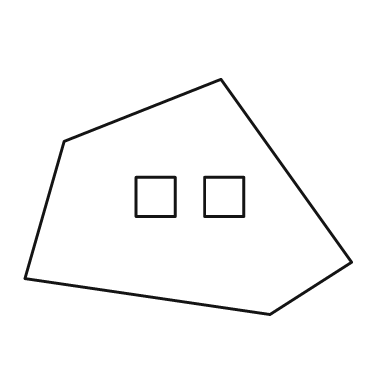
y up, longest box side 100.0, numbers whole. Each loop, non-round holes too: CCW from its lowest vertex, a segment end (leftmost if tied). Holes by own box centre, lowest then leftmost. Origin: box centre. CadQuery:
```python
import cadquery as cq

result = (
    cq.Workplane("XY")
    .moveTo(25.0, -36.0)
    .lineTo(50.0, -20.0)
    .lineTo(10.0, 36.0)
    .lineTo(-38.0, 17.0)
    .lineTo(-50.0, -25.0)
    .close()
    .moveTo(-16.0, -6.0)
    .lineTo(-4.0, -6.0)
    .lineTo(-4.0, 6.0)
    .lineTo(-16.0, 6.0)
    .close()
    .moveTo(5.0, -6.0)
    .lineTo(17.0, -6.0)
    .lineTo(17.0, 6.0)
    .lineTo(5.0, 6.0)
    .close()
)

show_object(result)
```